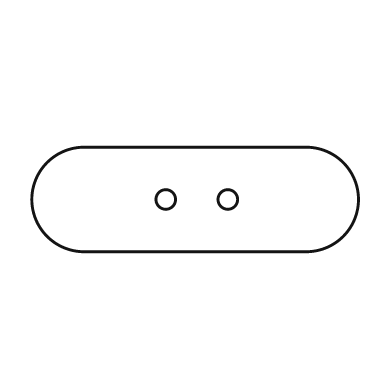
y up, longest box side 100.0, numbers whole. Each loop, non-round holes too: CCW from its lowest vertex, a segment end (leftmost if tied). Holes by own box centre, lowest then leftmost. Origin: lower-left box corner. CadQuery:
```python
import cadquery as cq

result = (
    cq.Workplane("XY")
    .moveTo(16.0, 0.0)
    .lineTo(84.0, 0.0)
    .threePointArc((100.0, 16.0), (84.0, 32.0))
    .lineTo(16.0, 32.0)
    .threePointArc((0.0, 16.0), (16.0, 0.0))
    .close()
    .moveTo(41.0, 16.0)
    .circle(3.0)
    .moveTo(60.0, 16.0)
    .circle(3.0)
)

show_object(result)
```